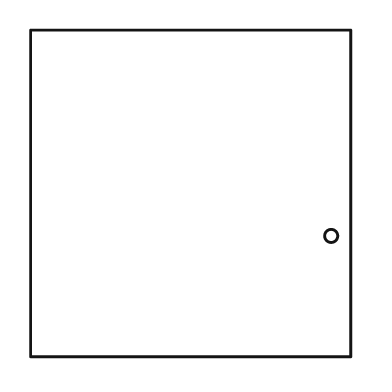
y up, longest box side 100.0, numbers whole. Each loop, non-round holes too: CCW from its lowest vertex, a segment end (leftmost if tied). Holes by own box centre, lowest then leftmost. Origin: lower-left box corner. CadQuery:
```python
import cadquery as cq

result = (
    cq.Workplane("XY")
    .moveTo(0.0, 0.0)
    .lineTo(98.0, 0.0)
    .lineTo(98.0, 100.0)
    .lineTo(0.0, 100.0)
    .close()
    .moveTo(92.0, 37.0)
    .circle(2.0)
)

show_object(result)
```